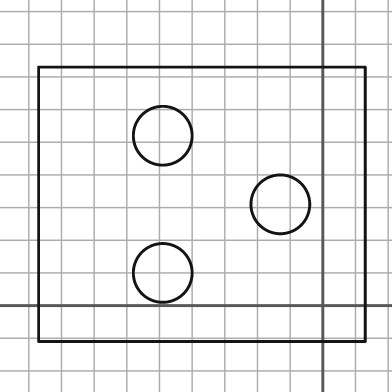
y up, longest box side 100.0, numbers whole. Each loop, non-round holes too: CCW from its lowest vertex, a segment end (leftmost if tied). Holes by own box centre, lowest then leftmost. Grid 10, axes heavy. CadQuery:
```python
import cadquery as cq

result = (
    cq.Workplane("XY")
    .moveTo(-87.0, -11.0)
    .lineTo(13.0, -11.0)
    .lineTo(13.0, 73.0)
    .lineTo(-87.0, 73.0)
    .close()
    .moveTo(-49.0, 10.0)
    .circle(9.0)
    .moveTo(-13.0, 31.0)
    .circle(9.0)
    .moveTo(-49.0, 52.0)
    .circle(9.0)
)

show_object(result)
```